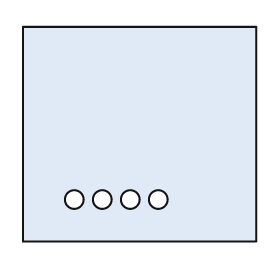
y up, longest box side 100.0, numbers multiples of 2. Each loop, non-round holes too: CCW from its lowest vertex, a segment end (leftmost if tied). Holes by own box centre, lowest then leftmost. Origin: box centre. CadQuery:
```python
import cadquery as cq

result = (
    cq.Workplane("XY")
    .moveTo(-50.0, -46.0)
    .lineTo(50.0, -46.0)
    .lineTo(50.0, 46.0)
    .lineTo(-50.0, 46.0)
    .close()
    .moveTo(-28.0, -28.0)
    .circle(4.0)
    .moveTo(-16.0, -28.0)
    .circle(4.0)
    .moveTo(-4.0, -28.0)
    .circle(4.0)
    .moveTo(8.0, -28.0)
    .circle(4.0)
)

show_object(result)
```